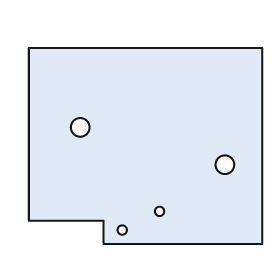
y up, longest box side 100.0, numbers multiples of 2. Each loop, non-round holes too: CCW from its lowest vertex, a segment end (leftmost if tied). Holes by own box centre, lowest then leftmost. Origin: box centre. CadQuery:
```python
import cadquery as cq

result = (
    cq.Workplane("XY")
    .moveTo(-18.0, -42.0)
    .lineTo(50.0, -42.0)
    .lineTo(50.0, 42.0)
    .lineTo(-50.0, 42.0)
    .lineTo(-50.0, -32.0)
    .lineTo(-18.0, -32.0)
    .close()
    .moveTo(-10.0, -36.0)
    .circle(2.0)
    .moveTo(6.0, -28.0)
    .circle(2.0)
    .moveTo(34.0, -8.0)
    .circle(4.0)
    .moveTo(-28.0, 8.0)
    .circle(4.0)
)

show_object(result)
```